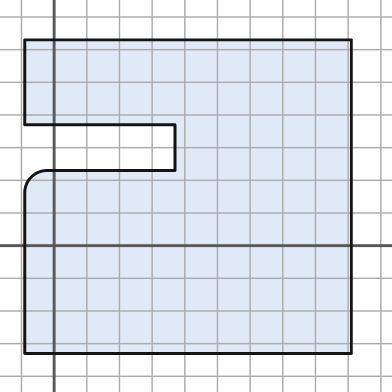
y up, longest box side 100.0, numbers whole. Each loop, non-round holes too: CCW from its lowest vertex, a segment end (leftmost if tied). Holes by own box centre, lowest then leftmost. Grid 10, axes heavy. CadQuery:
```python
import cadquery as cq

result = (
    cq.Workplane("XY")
    .moveTo(-9.0, -33.0)
    .lineTo(91.0, -33.0)
    .lineTo(91.0, 63.0)
    .lineTo(-9.0, 63.0)
    .lineTo(-9.0, 37.0)
    .lineTo(37.0, 37.0)
    .lineTo(37.0, 23.0)
    .lineTo(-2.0, 23.0)
    .threePointArc((-7.0, 21.0), (-9.0, 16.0))
    .close()
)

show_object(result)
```